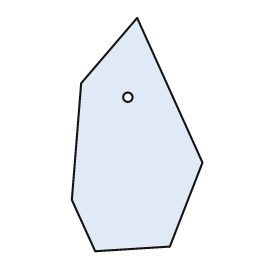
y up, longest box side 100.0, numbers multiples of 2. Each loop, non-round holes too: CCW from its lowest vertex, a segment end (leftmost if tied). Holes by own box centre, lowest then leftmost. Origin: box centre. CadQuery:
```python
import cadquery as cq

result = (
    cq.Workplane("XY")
    .moveTo(-18.0, -50.0)
    .lineTo(14.0, -48.0)
    .lineTo(28.0, -12.0)
    .lineTo(0.0, 50.0)
    .lineTo(-24.0, 22.0)
    .lineTo(-28.0, -28.0)
    .close()
    .moveTo(-4.0, 16.0)
    .circle(2.0)
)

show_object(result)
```